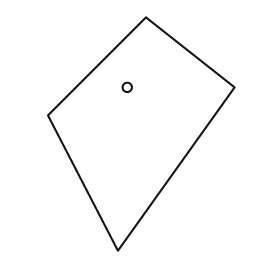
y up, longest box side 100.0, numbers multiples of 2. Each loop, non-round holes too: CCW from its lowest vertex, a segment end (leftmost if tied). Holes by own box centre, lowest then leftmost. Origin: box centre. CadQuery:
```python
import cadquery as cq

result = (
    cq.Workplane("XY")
    .moveTo(-10.0, -50.0)
    .lineTo(40.0, 20.0)
    .lineTo(2.0, 50.0)
    .lineTo(-40.0, 8.0)
    .close()
    .moveTo(-6.0, 20.0)
    .circle(2.0)
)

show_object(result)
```